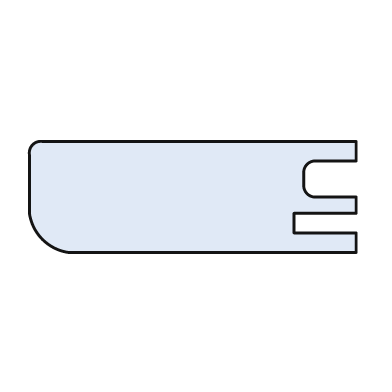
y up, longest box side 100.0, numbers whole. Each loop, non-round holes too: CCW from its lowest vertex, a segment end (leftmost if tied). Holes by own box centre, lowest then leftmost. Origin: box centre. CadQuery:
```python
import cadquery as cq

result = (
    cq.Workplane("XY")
    .moveTo(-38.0, -17.0)
    .lineTo(50.0, -17.0)
    .lineTo(50.0, -11.0)
    .lineTo(31.0, -11.0)
    .lineTo(31.0, -5.0)
    .lineTo(50.0, -5.0)
    .lineTo(50.0, 0.0)
    .lineTo(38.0, 0.0)
    .threePointArc((35.0, 1.0), (34.0, 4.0))
    .lineTo(34.0, 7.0)
    .threePointArc((35.0, 10.0), (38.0, 11.0))
    .lineTo(50.0, 11.0)
    .lineTo(50.0, 17.0)
    .lineTo(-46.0, 17.0)
    .threePointArc((-49.0, 16.0), (-50.0, 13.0))
    .lineTo(-50.0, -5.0)
    .threePointArc((-46.0, -13.0), (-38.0, -17.0))
    .close()
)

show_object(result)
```